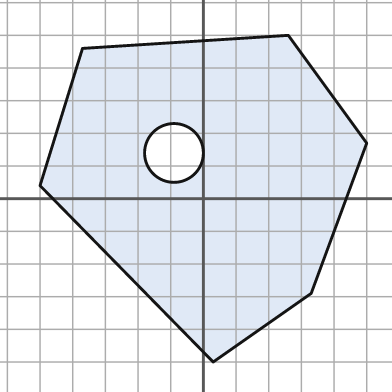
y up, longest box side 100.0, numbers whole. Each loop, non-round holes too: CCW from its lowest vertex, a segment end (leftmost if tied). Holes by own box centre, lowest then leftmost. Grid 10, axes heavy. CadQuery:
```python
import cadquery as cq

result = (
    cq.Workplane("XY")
    .moveTo(3.0, -50.0)
    .lineTo(33.0, -29.0)
    .lineTo(50.0, 17.0)
    .lineTo(26.0, 50.0)
    .lineTo(-37.0, 46.0)
    .lineTo(-50.0, 4.0)
    .close()
    .moveTo(-9.0, 14.0)
    .circle(9.0)
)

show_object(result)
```